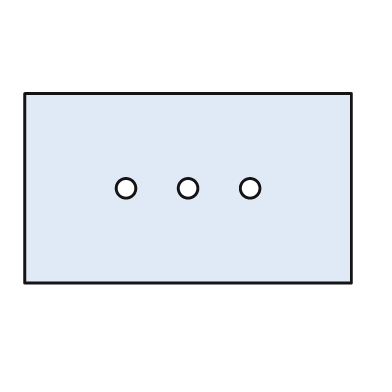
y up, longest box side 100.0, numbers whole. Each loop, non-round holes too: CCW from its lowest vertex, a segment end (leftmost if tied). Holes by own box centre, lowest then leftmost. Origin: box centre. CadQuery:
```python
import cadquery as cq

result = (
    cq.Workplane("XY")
    .moveTo(-50.0, -29.0)
    .lineTo(50.0, -29.0)
    .lineTo(50.0, 29.0)
    .lineTo(-50.0, 29.0)
    .close()
    .moveTo(-19.0, 0.0)
    .circle(3.0)
    .moveTo(0.0, 0.0)
    .circle(3.0)
    .moveTo(19.0, 0.0)
    .circle(3.0)
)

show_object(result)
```